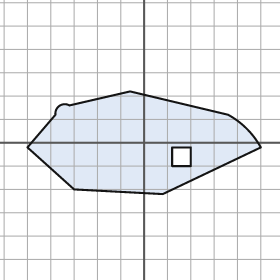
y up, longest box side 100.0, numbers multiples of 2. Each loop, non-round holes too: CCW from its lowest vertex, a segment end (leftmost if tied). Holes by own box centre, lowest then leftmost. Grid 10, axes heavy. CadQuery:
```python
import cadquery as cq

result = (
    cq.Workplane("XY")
    .moveTo(8.0, -22.0)
    .lineTo(50.0, -2.0)
    .threePointArc((44.0, 6.0), (36.0, 12.0))
    .lineTo(-6.0, 22.0)
    .lineTo(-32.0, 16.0)
    .threePointArc((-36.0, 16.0), (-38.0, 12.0))
    .lineTo(-50.0, -2.0)
    .lineTo(-30.0, -20.0)
    .close()
    .moveTo(12.0, -10.0)
    .lineTo(20.0, -10.0)
    .lineTo(20.0, -2.0)
    .lineTo(12.0, -2.0)
    .close()
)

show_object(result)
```